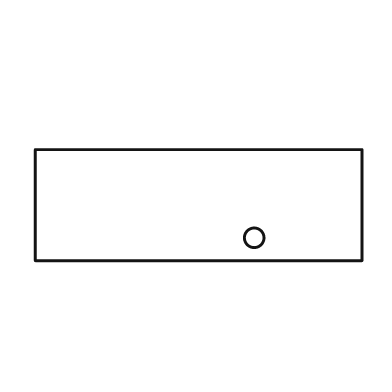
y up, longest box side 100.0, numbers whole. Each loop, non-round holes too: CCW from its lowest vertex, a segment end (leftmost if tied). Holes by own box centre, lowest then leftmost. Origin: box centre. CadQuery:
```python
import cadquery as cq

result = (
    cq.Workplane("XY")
    .moveTo(-50.0, -17.0)
    .lineTo(50.0, -17.0)
    .lineTo(50.0, 17.0)
    .lineTo(-50.0, 17.0)
    .close()
    .moveTo(17.0, -10.0)
    .circle(3.0)
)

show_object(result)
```